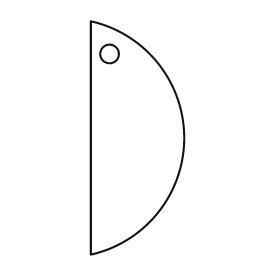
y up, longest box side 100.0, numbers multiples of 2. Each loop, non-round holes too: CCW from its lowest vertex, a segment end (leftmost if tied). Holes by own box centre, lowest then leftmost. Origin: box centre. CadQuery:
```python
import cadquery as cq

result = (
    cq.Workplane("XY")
    .moveTo(-20.0, -50.0)
    .threePointArc((20.0, 0.0), (-20.0, 50.0))
    .close()
    .moveTo(-12.0, 36.0)
    .circle(4.0)
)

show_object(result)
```